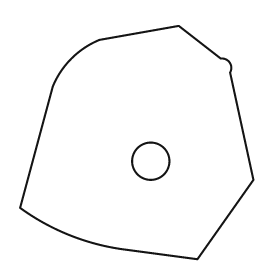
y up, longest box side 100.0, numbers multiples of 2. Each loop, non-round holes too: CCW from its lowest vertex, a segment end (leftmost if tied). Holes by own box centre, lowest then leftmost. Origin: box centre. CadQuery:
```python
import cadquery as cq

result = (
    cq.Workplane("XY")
    .moveTo(26.0, -50.0)
    .lineTo(50.0, -16.0)
    .lineTo(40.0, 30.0)
    .threePointArc((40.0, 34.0), (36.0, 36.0))
    .lineTo(18.0, 50.0)
    .lineTo(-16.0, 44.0)
    .threePointArc((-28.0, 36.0), (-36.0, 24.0))
    .lineTo(-50.0, -28.0)
    .threePointArc((-28.0, -40.0), (-4.0, -46.0))
    .close()
    .moveTo(6.0, -8.0)
    .circle(8.0)
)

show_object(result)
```